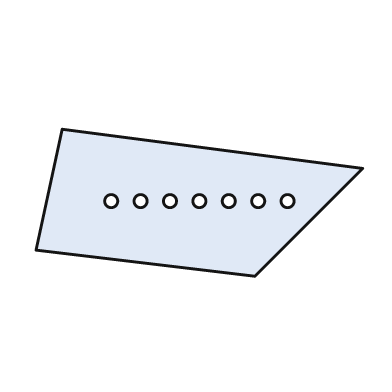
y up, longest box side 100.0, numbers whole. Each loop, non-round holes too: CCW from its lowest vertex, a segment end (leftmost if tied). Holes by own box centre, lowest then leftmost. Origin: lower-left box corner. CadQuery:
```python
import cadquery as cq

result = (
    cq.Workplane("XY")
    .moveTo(67.0, 0.0)
    .lineTo(100.0, 33.0)
    .lineTo(8.0, 45.0)
    .lineTo(0.0, 8.0)
    .close()
    .moveTo(23.0, 23.0)
    .circle(2.0)
    .moveTo(32.0, 23.0)
    .circle(2.0)
    .moveTo(41.0, 23.0)
    .circle(2.0)
    .moveTo(50.0, 23.0)
    .circle(2.0)
    .moveTo(59.0, 23.0)
    .circle(2.0)
    .moveTo(68.0, 23.0)
    .circle(2.0)
    .moveTo(77.0, 23.0)
    .circle(2.0)
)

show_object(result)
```